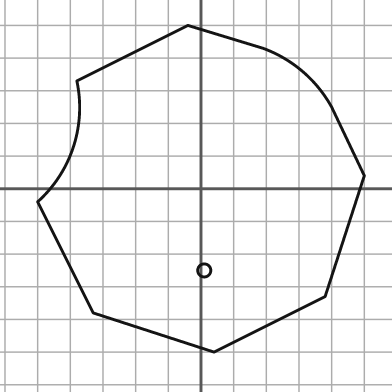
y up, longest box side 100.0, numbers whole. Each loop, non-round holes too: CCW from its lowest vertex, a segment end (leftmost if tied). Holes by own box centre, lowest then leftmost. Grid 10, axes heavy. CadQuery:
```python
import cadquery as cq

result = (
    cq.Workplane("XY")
    .moveTo(4.0, -50.0)
    .lineTo(38.0, -33.0)
    .lineTo(50.0, 4.0)
    .lineTo(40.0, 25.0)
    .threePointArc((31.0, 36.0), (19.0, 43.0))
    .lineTo(-4.0, 50.0)
    .lineTo(-38.0, 33.0)
    .threePointArc((-39.0, 13.0), (-50.0, -4.0))
    .lineTo(-33.0, -38.0)
    .close()
    .moveTo(1.0, -25.0)
    .circle(2.0)
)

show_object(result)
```